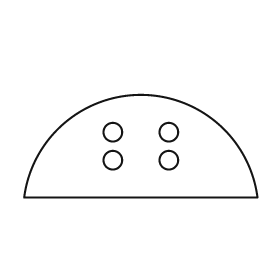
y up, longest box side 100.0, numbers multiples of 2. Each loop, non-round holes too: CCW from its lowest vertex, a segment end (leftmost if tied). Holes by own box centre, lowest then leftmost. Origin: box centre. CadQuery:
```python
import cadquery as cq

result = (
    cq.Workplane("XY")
    .moveTo(-50.0, -22.0)
    .lineTo(50.0, -22.0)
    .threePointArc((0.0, 22.0), (-50.0, -22.0))
    .close()
    .moveTo(-12.0, -6.0)
    .circle(4.0)
    .moveTo(12.0, -6.0)
    .circle(4.0)
    .moveTo(-12.0, 6.0)
    .circle(4.0)
    .moveTo(12.0, 6.0)
    .circle(4.0)
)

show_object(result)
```